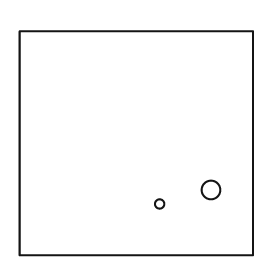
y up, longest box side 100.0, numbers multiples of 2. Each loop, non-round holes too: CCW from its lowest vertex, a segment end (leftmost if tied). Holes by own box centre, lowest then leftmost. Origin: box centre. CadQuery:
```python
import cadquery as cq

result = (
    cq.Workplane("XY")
    .moveTo(-50.0, -48.0)
    .lineTo(50.0, -48.0)
    .lineTo(50.0, 48.0)
    .lineTo(-50.0, 48.0)
    .close()
    .moveTo(10.0, -26.0)
    .circle(2.0)
    .moveTo(32.0, -20.0)
    .circle(4.0)
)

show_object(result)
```